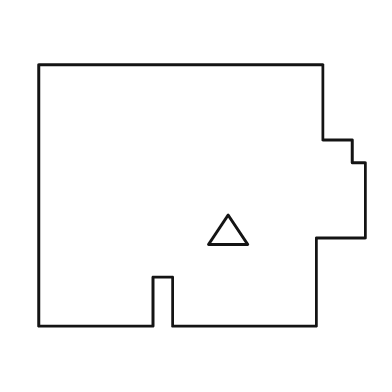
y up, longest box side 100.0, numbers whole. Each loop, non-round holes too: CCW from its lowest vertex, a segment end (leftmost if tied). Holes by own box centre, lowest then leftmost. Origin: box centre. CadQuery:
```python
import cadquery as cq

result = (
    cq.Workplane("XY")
    .moveTo(-50.0, -40.0)
    .lineTo(-15.0, -40.0)
    .lineTo(-15.0, -25.0)
    .lineTo(-9.0, -25.0)
    .lineTo(-9.0, -40.0)
    .lineTo(35.0, -40.0)
    .lineTo(35.0, -13.0)
    .lineTo(50.0, -13.0)
    .lineTo(50.0, 10.0)
    .lineTo(46.0, 10.0)
    .lineTo(46.0, 17.0)
    .lineTo(37.0, 17.0)
    .lineTo(37.0, 40.0)
    .lineTo(-50.0, 40.0)
    .close()
    .moveTo(2.0, -15.0)
    .lineTo(14.0, -15.0)
    .lineTo(8.0, -6.0)
    .close()
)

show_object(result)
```